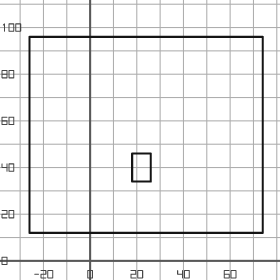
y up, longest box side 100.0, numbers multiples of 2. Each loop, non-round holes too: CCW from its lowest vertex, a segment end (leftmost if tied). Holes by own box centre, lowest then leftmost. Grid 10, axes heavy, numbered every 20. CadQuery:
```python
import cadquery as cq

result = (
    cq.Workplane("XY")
    .moveTo(-26.0, 12.0)
    .lineTo(74.0, 12.0)
    .lineTo(74.0, 96.0)
    .lineTo(-26.0, 96.0)
    .close()
    .moveTo(18.0, 34.0)
    .lineTo(26.0, 34.0)
    .lineTo(26.0, 46.0)
    .lineTo(18.0, 46.0)
    .close()
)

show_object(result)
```